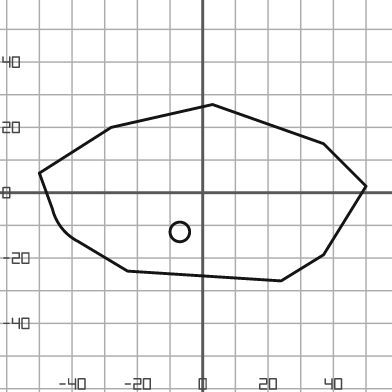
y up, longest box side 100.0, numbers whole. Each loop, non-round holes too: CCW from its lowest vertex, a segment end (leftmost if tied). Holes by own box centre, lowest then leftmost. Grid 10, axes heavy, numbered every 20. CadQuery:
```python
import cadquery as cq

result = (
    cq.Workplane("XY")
    .moveTo(24.0, -27.0)
    .lineTo(37.0, -19.0)
    .lineTo(50.0, 2.0)
    .lineTo(37.0, 15.0)
    .lineTo(3.0, 27.0)
    .lineTo(-28.0, 20.0)
    .lineTo(-50.0, 6.0)
    .lineTo(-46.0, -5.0)
    .threePointArc((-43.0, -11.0), (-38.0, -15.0))
    .lineTo(-23.0, -24.0)
    .close()
    .moveTo(-7.0, -12.0)
    .circle(3.0)
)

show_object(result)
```